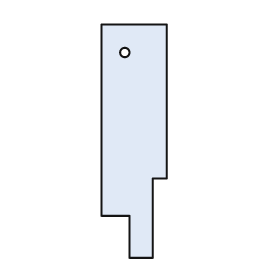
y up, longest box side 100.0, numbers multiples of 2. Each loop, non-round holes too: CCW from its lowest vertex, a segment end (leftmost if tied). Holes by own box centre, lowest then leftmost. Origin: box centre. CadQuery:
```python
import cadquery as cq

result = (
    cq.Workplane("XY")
    .moveTo(-2.0, -50.0)
    .lineTo(8.0, -50.0)
    .lineTo(8.0, -16.0)
    .lineTo(14.0, -16.0)
    .lineTo(14.0, 50.0)
    .lineTo(-14.0, 50.0)
    .lineTo(-14.0, -32.0)
    .lineTo(-2.0, -32.0)
    .close()
    .moveTo(-4.0, 38.0)
    .circle(2.0)
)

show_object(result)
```